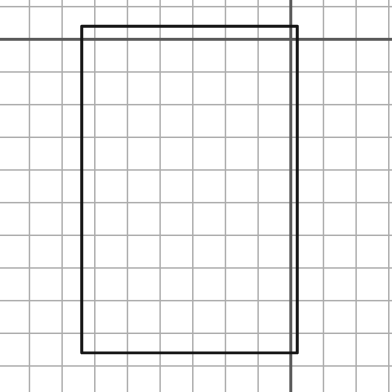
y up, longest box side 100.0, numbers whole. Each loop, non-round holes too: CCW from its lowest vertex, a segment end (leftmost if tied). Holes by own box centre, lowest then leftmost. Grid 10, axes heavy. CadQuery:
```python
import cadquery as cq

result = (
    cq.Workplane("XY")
    .moveTo(-64.0, -96.0)
    .lineTo(2.0, -96.0)
    .lineTo(2.0, 4.0)
    .lineTo(-64.0, 4.0)
    .close()
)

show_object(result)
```